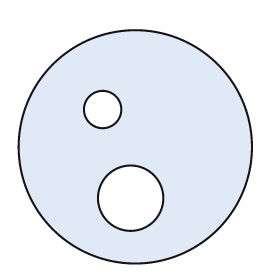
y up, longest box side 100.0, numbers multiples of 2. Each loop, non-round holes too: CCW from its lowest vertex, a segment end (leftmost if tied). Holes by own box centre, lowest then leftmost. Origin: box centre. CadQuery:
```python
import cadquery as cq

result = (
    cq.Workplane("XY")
    .moveTo(0.0, 0.0)
    .circle(50.0)
    .moveTo(-2.0, -22.0)
    .circle(14.0)
    .moveTo(-14.0, 16.0)
    .circle(8.0)
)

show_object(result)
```